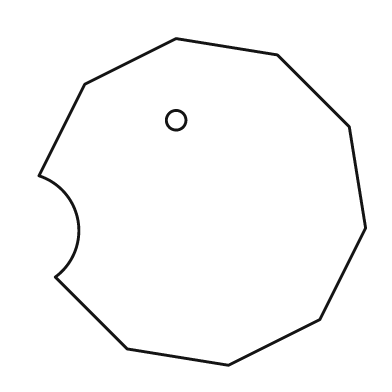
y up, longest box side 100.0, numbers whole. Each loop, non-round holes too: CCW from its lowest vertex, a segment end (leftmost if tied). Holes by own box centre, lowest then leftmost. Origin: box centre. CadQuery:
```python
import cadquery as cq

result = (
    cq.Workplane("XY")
    .moveTo(8.0, -50.0)
    .lineTo(36.0, -36.0)
    .lineTo(50.0, -8.0)
    .lineTo(45.0, 23.0)
    .lineTo(23.0, 45.0)
    .lineTo(-8.0, 50.0)
    .lineTo(-36.0, 36.0)
    .lineTo(-50.0, 8.0)
    .threePointArc((-38.0, -6.0), (-45.0, -23.0))
    .lineTo(-23.0, -45.0)
    .close()
    .moveTo(-8.0, 25.0)
    .circle(3.0)
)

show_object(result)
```